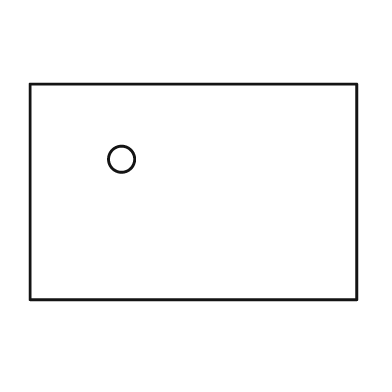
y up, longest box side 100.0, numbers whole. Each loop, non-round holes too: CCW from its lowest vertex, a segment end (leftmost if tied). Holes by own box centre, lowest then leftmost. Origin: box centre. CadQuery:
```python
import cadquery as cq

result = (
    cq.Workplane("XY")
    .moveTo(-50.0, -33.0)
    .lineTo(50.0, -33.0)
    .lineTo(50.0, 33.0)
    .lineTo(-50.0, 33.0)
    .close()
    .moveTo(-22.0, 10.0)
    .circle(4.0)
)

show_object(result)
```